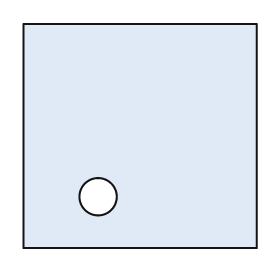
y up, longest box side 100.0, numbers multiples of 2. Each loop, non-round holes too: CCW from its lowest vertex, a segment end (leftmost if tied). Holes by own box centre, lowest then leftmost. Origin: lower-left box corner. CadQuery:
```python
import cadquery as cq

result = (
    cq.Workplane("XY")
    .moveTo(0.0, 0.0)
    .lineTo(100.0, 0.0)
    .lineTo(100.0, 96.0)
    .lineTo(0.0, 96.0)
    .close()
    .moveTo(32.0, 22.0)
    .circle(8.0)
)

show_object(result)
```